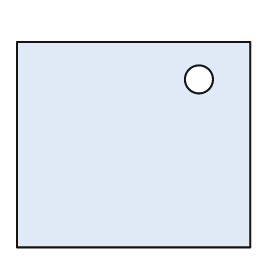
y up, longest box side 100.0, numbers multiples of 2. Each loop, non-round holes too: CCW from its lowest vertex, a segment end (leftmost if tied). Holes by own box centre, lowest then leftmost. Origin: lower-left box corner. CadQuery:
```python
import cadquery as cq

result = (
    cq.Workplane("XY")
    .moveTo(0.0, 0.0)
    .lineTo(100.0, 0.0)
    .lineTo(100.0, 88.0)
    .lineTo(0.0, 88.0)
    .close()
    .moveTo(78.0, 72.0)
    .circle(6.0)
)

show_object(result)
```